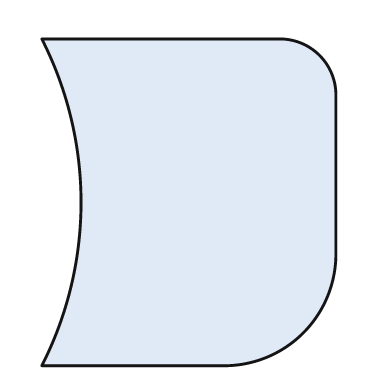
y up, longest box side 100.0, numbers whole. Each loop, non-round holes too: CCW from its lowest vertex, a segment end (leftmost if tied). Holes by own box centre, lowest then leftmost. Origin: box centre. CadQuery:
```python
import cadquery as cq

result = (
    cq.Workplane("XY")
    .moveTo(-45.0, -50.0)
    .lineTo(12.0, -50.0)
    .threePointArc((35.0, -40.0), (45.0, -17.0))
    .lineTo(45.0, 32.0)
    .threePointArc((40.0, 45.0), (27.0, 50.0))
    .lineTo(-45.0, 50.0)
    .threePointArc((-33.0, 0.0), (-45.0, -50.0))
    .close()
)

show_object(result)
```